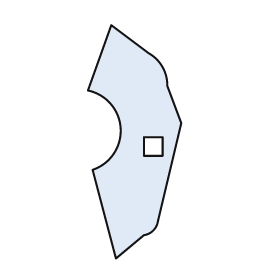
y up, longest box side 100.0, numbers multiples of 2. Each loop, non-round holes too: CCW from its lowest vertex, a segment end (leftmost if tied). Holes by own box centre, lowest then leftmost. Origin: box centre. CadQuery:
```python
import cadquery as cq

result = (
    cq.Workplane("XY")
    .moveTo(-8.0, -50.0)
    .lineTo(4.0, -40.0)
    .threePointArc((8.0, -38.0), (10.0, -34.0))
    .lineTo(20.0, 8.0)
    .lineTo(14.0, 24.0)
    .threePointArc((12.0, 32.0), (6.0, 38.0))
    .lineTo(-10.0, 50.0)
    .lineTo(-20.0, 22.0)
    .threePointArc((-6.0, 6.0), (-18.0, -12.0))
    .close()
    .moveTo(4.0, -6.0)
    .lineTo(12.0, -6.0)
    .lineTo(12.0, 2.0)
    .lineTo(4.0, 2.0)
    .close()
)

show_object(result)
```